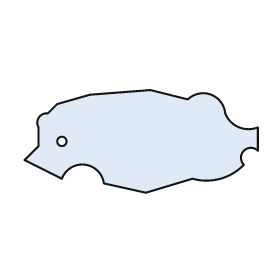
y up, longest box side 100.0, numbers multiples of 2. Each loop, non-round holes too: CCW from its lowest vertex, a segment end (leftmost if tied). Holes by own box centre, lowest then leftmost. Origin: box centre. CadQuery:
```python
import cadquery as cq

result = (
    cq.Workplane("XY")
    .moveTo(2.0, -22.0)
    .lineTo(22.0, -16.0)
    .threePointArc((34.0, -16.0), (44.0, -10.0))
    .threePointArc((44.0, -4.0), (50.0, -4.0))
    .lineTo(50.0, 6.0)
    .threePointArc((42.0, 6.0), (36.0, 12.0))
    .threePointArc((30.0, 20.0), (20.0, 18.0))
    .lineTo(4.0, 22.0)
    .lineTo(-22.0, 20.0)
    .lineTo(-36.0, 16.0)
    .lineTo(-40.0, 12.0)
    .threePointArc((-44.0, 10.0), (-44.0, 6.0))
    .lineTo(-44.0, -2.0)
    .lineTo(-50.0, -8.0)
    .lineTo(-34.0, -16.0)
    .threePointArc((-24.0, -10.0), (-16.0, -18.0))
    .close()
    .moveTo(-34.0, 0.0)
    .circle(2.0)
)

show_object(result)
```